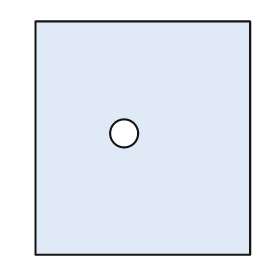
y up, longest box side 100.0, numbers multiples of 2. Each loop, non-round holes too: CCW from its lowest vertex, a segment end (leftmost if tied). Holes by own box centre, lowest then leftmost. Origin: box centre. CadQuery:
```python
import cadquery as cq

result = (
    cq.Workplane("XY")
    .moveTo(-46.0, -50.0)
    .lineTo(46.0, -50.0)
    .lineTo(46.0, 50.0)
    .lineTo(-46.0, 50.0)
    .close()
    .moveTo(-8.0, 2.0)
    .circle(6.0)
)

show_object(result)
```